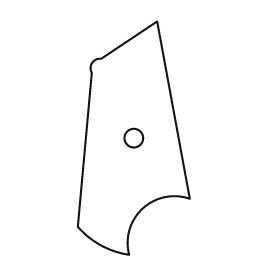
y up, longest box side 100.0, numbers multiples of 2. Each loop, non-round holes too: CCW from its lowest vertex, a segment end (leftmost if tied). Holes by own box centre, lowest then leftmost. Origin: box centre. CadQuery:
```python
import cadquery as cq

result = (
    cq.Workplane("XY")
    .moveTo(-2.0, -50.0)
    .threePointArc((4.0, -30.0), (24.0, -26.0))
    .lineTo(10.0, 50.0)
    .lineTo(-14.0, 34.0)
    .threePointArc((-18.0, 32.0), (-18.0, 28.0))
    .lineTo(-24.0, -38.0)
    .threePointArc((-14.0, -46.0), (-2.0, -50.0))
    .close()
    .moveTo(0.0, 0.0)
    .circle(4.0)
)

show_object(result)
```